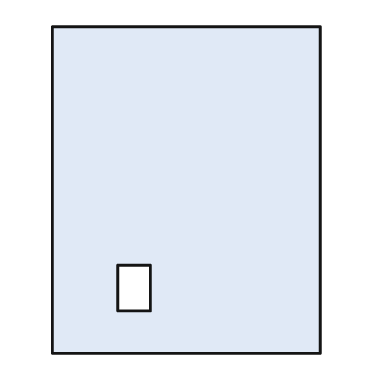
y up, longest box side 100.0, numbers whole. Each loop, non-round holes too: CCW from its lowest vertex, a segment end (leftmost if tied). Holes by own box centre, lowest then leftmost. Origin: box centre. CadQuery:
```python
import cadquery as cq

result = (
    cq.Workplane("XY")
    .moveTo(-41.0, -50.0)
    .lineTo(41.0, -50.0)
    .lineTo(41.0, 50.0)
    .lineTo(-41.0, 50.0)
    .close()
    .moveTo(-21.0, -37.0)
    .lineTo(-11.0, -37.0)
    .lineTo(-11.0, -23.0)
    .lineTo(-21.0, -23.0)
    .close()
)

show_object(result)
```